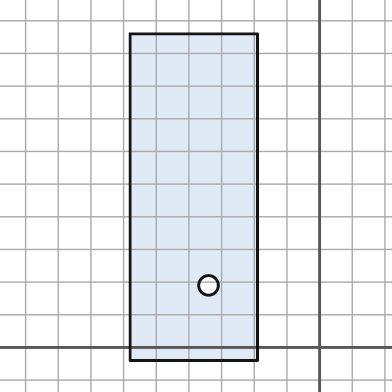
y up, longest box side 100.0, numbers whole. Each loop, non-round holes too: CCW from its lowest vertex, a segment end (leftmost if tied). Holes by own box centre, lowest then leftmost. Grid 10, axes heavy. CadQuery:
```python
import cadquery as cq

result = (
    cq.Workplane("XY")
    .moveTo(-58.0, -4.0)
    .lineTo(-19.0, -4.0)
    .lineTo(-19.0, 96.0)
    .lineTo(-58.0, 96.0)
    .close()
    .moveTo(-34.0, 19.0)
    .circle(3.0)
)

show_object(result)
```